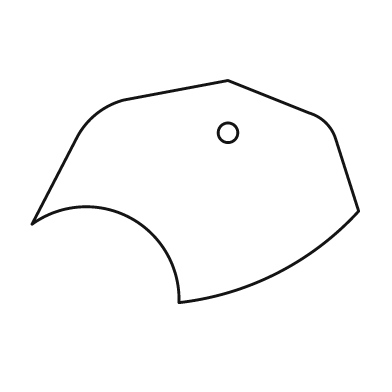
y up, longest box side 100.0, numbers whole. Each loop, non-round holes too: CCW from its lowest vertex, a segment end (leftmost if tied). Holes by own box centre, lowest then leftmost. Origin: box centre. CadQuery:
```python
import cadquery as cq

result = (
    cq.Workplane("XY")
    .moveTo(-5.0, -34.0)
    .threePointArc((25.0, -25.0), (50.0, -6.0))
    .lineTo(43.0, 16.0)
    .threePointArc((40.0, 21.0), (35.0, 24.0))
    .lineTo(10.0, 34.0)
    .lineTo(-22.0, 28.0)
    .threePointArc((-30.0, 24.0), (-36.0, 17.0))
    .lineTo(-50.0, -10.0)
    .threePointArc((-20.0, -8.0), (-5.0, -34.0))
    .close()
    .moveTo(10.0, 18.0)
    .circle(3.0)
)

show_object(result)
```